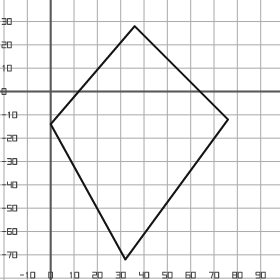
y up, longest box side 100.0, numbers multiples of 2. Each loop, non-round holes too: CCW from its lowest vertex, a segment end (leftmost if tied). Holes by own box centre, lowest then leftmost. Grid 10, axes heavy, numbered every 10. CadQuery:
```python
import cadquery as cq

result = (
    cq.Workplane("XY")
    .moveTo(32.0, -72.0)
    .lineTo(76.0, -12.0)
    .lineTo(36.0, 28.0)
    .lineTo(0.0, -14.0)
    .close()
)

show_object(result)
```